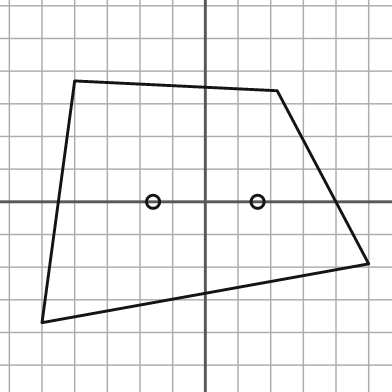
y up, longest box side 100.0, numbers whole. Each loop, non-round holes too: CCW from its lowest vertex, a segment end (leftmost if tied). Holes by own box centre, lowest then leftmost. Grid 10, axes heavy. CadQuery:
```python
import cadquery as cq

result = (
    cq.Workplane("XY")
    .moveTo(-50.0, -37.0)
    .lineTo(50.0, -19.0)
    .lineTo(22.0, 34.0)
    .lineTo(-40.0, 37.0)
    .close()
    .moveTo(-16.0, 0.0)
    .circle(2.0)
    .moveTo(16.0, 0.0)
    .circle(2.0)
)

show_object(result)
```